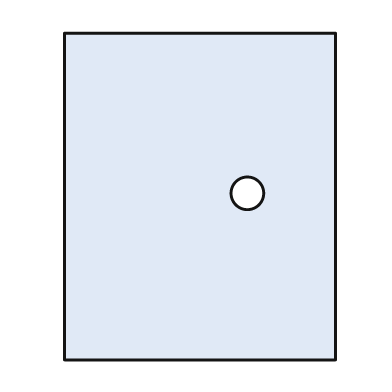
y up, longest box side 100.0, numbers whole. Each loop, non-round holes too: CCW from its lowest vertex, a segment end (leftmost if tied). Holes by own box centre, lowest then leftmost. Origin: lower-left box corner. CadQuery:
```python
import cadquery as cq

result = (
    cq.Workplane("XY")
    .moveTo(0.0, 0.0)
    .lineTo(83.0, 0.0)
    .lineTo(83.0, 100.0)
    .lineTo(0.0, 100.0)
    .close()
    .moveTo(56.0, 51.0)
    .circle(5.0)
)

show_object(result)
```